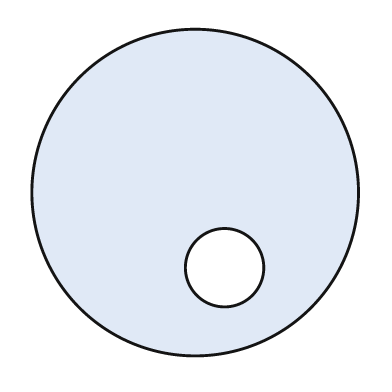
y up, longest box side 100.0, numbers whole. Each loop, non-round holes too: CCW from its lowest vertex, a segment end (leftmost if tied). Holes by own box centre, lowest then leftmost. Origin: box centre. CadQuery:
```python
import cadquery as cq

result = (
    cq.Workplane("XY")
    .moveTo(0.0, 0.0)
    .circle(50.0)
    .moveTo(9.0, -23.0)
    .circle(12.0)
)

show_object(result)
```